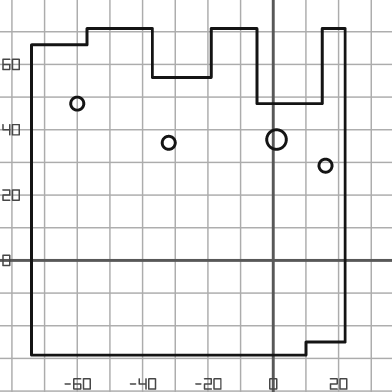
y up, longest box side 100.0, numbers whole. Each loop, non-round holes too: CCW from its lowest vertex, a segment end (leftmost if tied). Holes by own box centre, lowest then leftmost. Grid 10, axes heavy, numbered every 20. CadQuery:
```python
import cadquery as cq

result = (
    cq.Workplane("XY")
    .moveTo(-74.0, -29.0)
    .lineTo(10.0, -29.0)
    .lineTo(10.0, -25.0)
    .lineTo(22.0, -25.0)
    .lineTo(22.0, 71.0)
    .lineTo(15.0, 71.0)
    .lineTo(15.0, 48.0)
    .lineTo(-5.0, 48.0)
    .lineTo(-5.0, 71.0)
    .lineTo(-19.0, 71.0)
    .lineTo(-19.0, 56.0)
    .lineTo(-37.0, 56.0)
    .lineTo(-37.0, 71.0)
    .lineTo(-57.0, 71.0)
    .lineTo(-57.0, 66.0)
    .lineTo(-74.0, 66.0)
    .close()
    .moveTo(16.0, 29.0)
    .circle(2.0)
    .moveTo(-32.0, 36.0)
    .circle(2.0)
    .moveTo(1.0, 37.0)
    .circle(3.0)
    .moveTo(-60.0, 48.0)
    .circle(2.0)
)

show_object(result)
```